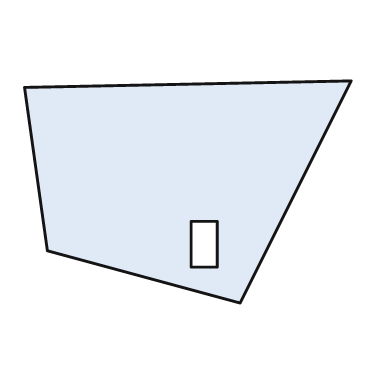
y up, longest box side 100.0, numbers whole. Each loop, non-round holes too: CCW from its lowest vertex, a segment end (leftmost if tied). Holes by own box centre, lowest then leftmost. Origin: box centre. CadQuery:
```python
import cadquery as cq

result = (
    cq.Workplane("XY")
    .moveTo(16.0, -34.0)
    .lineTo(50.0, 34.0)
    .lineTo(-50.0, 32.0)
    .lineTo(-43.0, -18.0)
    .close()
    .moveTo(1.0, -23.0)
    .lineTo(9.0, -23.0)
    .lineTo(9.0, -9.0)
    .lineTo(1.0, -9.0)
    .close()
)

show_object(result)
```